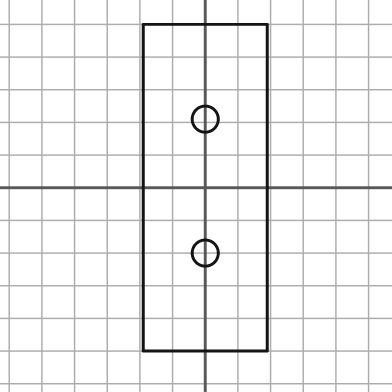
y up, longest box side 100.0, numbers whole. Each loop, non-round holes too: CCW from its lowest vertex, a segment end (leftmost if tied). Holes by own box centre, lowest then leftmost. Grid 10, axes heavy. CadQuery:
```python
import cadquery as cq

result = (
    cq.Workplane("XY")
    .moveTo(-19.0, -50.0)
    .lineTo(19.0, -50.0)
    .lineTo(19.0, 50.0)
    .lineTo(-19.0, 50.0)
    .close()
    .moveTo(0.0, -20.0)
    .circle(4.0)
    .moveTo(0.0, 21.0)
    .circle(4.0)
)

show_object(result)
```